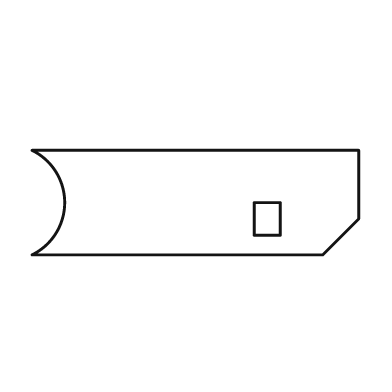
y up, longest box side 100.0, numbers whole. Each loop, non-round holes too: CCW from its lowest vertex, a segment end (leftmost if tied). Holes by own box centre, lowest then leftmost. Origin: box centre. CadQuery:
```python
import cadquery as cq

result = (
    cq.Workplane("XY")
    .moveTo(-50.0, -16.0)
    .lineTo(39.0, -16.0)
    .lineTo(50.0, -5.0)
    .lineTo(50.0, 16.0)
    .lineTo(-50.0, 16.0)
    .threePointArc((-40.0, 0.0), (-50.0, -16.0))
    .close()
    .moveTo(18.0, -10.0)
    .lineTo(26.0, -10.0)
    .lineTo(26.0, 0.0)
    .lineTo(18.0, 0.0)
    .close()
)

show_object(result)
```